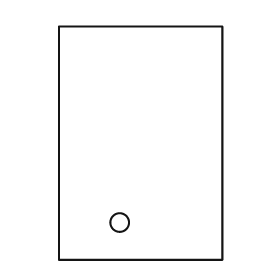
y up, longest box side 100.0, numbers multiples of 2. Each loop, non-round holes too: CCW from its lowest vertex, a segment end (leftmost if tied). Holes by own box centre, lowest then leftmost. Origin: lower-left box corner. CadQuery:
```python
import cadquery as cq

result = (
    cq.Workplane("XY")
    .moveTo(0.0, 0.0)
    .lineTo(70.0, 0.0)
    .lineTo(70.0, 100.0)
    .lineTo(0.0, 100.0)
    .close()
    .moveTo(26.0, 16.0)
    .circle(4.0)
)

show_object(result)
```